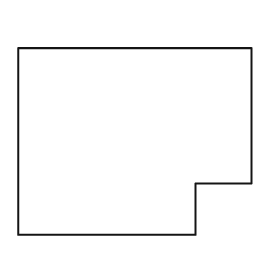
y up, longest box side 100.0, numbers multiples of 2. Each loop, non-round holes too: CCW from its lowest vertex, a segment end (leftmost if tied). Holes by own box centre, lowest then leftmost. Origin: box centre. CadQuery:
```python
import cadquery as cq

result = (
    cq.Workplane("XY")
    .moveTo(-50.0, -40.0)
    .lineTo(26.0, -40.0)
    .lineTo(26.0, -18.0)
    .lineTo(50.0, -18.0)
    .lineTo(50.0, 40.0)
    .lineTo(-50.0, 40.0)
    .close()
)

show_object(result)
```